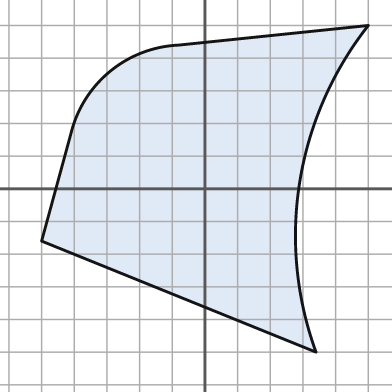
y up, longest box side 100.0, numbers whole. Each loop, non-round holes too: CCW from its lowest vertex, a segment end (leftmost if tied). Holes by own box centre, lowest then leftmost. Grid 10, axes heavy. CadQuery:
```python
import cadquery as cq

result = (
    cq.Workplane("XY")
    .moveTo(34.0, -50.0)
    .threePointArc((29.0, 2.0), (50.0, 50.0))
    .lineTo(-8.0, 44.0)
    .threePointArc((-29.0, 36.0), (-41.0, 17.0))
    .lineTo(-50.0, -16.0)
    .close()
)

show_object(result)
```